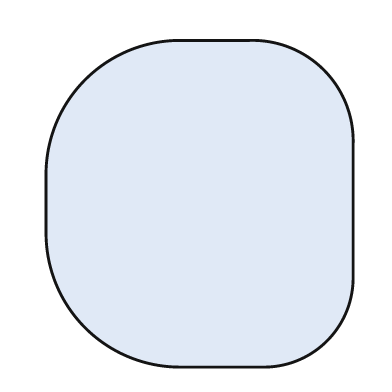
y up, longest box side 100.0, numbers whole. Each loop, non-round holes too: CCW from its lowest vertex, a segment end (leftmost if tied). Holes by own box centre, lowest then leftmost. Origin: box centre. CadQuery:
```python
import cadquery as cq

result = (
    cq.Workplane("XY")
    .moveTo(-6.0, -50.0)
    .lineTo(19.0, -50.0)
    .threePointArc((39.0, -42.0), (47.0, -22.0))
    .lineTo(47.0, 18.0)
    .threePointArc((38.0, 41.0), (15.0, 50.0))
    .lineTo(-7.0, 50.0)
    .threePointArc((-35.0, 38.0), (-47.0, 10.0))
    .lineTo(-47.0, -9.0)
    .threePointArc((-35.0, -38.0), (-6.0, -50.0))
    .close()
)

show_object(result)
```